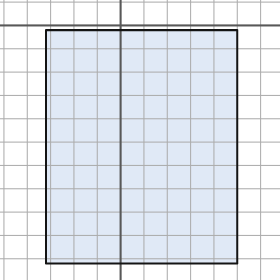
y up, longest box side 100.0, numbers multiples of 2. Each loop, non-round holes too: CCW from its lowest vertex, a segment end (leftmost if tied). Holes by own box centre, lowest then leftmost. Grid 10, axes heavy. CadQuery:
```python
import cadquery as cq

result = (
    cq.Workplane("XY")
    .moveTo(-32.0, -102.0)
    .lineTo(50.0, -102.0)
    .lineTo(50.0, -2.0)
    .lineTo(-32.0, -2.0)
    .close()
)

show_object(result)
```